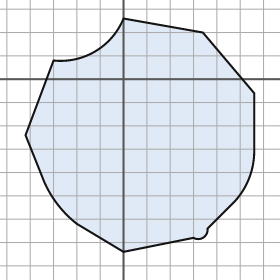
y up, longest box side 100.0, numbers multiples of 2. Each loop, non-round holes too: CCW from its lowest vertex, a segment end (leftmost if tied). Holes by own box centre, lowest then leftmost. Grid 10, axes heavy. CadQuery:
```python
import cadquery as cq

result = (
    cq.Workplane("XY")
    .moveTo(0.0, -74.0)
    .lineTo(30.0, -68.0)
    .threePointArc((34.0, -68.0), (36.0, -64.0))
    .lineTo(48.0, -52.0)
    .threePointArc((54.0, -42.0), (56.0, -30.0))
    .lineTo(56.0, -6.0)
    .lineTo(34.0, 20.0)
    .lineTo(0.0, 26.0)
    .threePointArc((-12.0, 12.0), (-30.0, 8.0))
    .lineTo(-42.0, -24.0)
    .lineTo(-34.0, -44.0)
    .threePointArc((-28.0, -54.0), (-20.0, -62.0))
    .close()
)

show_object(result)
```